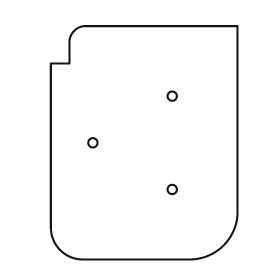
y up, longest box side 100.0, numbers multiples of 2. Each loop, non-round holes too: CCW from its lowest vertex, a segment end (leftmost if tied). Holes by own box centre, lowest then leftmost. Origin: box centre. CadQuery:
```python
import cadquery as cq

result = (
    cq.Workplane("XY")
    .moveTo(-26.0, -50.0)
    .lineTo(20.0, -50.0)
    .threePointArc((34.0, -44.0), (40.0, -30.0))
    .lineTo(40.0, 50.0)
    .lineTo(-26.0, 50.0)
    .threePointArc((-30.0, 48.0), (-32.0, 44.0))
    .lineTo(-32.0, 34.0)
    .lineTo(-40.0, 34.0)
    .lineTo(-40.0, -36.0)
    .threePointArc((-36.0, -46.0), (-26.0, -50.0))
    .close()
    .moveTo(12.0, -20.0)
    .circle(2.0)
    .moveTo(-22.0, 0.0)
    .circle(2.0)
    .moveTo(12.0, 20.0)
    .circle(2.0)
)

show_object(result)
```